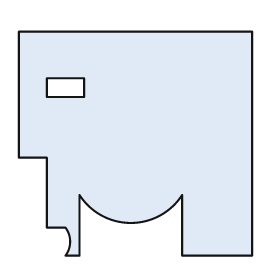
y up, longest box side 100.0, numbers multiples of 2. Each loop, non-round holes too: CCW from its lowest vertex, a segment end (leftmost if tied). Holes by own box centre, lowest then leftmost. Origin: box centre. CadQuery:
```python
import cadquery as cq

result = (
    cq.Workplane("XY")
    .moveTo(-30.0, -48.0)
    .lineTo(-24.0, -48.0)
    .lineTo(-24.0, -22.0)
    .threePointArc((-2.0, -34.0), (20.0, -22.0))
    .lineTo(20.0, -48.0)
    .lineTo(50.0, -48.0)
    .lineTo(50.0, 48.0)
    .lineTo(-50.0, 48.0)
    .lineTo(-50.0, -6.0)
    .lineTo(-38.0, -6.0)
    .lineTo(-38.0, -36.0)
    .lineTo(-30.0, -36.0)
    .threePointArc((-28.0, -42.0), (-30.0, -48.0))
    .close()
    .moveTo(-38.0, 20.0)
    .lineTo(-22.0, 20.0)
    .lineTo(-22.0, 28.0)
    .lineTo(-38.0, 28.0)
    .close()
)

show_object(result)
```